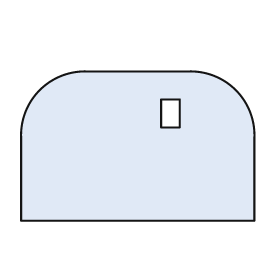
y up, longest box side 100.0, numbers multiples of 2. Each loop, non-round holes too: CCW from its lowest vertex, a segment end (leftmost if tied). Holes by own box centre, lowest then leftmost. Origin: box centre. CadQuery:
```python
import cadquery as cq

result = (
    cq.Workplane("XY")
    .moveTo(-50.0, -32.0)
    .lineTo(50.0, -32.0)
    .lineTo(50.0, 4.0)
    .threePointArc((42.0, 24.0), (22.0, 32.0))
    .lineTo(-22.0, 32.0)
    .threePointArc((-42.0, 24.0), (-50.0, 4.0))
    .close()
    .moveTo(10.0, 8.0)
    .lineTo(18.0, 8.0)
    .lineTo(18.0, 20.0)
    .lineTo(10.0, 20.0)
    .close()
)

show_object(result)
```